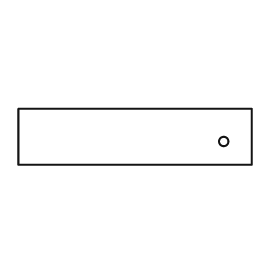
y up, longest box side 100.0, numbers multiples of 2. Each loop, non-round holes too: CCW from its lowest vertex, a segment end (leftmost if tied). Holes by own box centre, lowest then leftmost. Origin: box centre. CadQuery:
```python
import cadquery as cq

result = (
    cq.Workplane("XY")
    .moveTo(-50.0, -12.0)
    .lineTo(50.0, -12.0)
    .lineTo(50.0, 12.0)
    .lineTo(-50.0, 12.0)
    .close()
    .moveTo(38.0, -2.0)
    .circle(2.0)
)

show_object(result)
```